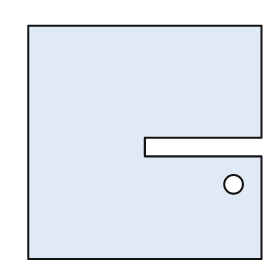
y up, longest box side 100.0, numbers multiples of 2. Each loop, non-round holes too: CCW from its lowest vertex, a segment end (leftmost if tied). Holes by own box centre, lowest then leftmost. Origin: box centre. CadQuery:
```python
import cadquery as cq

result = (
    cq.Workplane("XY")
    .moveTo(-50.0, -50.0)
    .lineTo(50.0, -50.0)
    .lineTo(50.0, -6.0)
    .lineTo(0.0, -6.0)
    .lineTo(0.0, 2.0)
    .lineTo(50.0, 2.0)
    .lineTo(50.0, 50.0)
    .lineTo(-50.0, 50.0)
    .close()
    .moveTo(38.0, -18.0)
    .circle(4.0)
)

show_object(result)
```